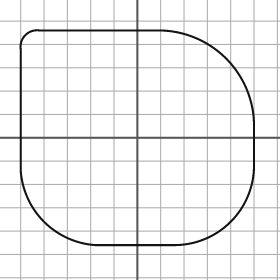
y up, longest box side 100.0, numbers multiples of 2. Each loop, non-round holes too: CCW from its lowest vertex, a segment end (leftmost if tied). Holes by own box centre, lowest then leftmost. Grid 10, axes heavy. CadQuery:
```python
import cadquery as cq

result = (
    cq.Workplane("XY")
    .moveTo(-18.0, -46.0)
    .lineTo(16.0, -46.0)
    .threePointArc((40.0, -36.0), (50.0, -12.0))
    .lineTo(50.0, 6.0)
    .threePointArc((38.0, 34.0), (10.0, 46.0))
    .lineTo(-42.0, 46.0)
    .threePointArc((-48.0, 44.0), (-50.0, 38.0))
    .lineTo(-50.0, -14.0)
    .threePointArc((-40.0, -36.0), (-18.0, -46.0))
    .close()
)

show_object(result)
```